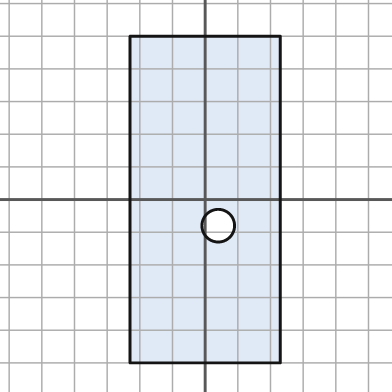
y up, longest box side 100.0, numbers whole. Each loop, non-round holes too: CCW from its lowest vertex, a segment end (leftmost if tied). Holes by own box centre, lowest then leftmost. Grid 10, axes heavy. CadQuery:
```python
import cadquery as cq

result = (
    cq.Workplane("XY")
    .moveTo(-23.0, -50.0)
    .lineTo(23.0, -50.0)
    .lineTo(23.0, 50.0)
    .lineTo(-23.0, 50.0)
    .close()
    .moveTo(4.0, -8.0)
    .circle(5.0)
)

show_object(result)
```